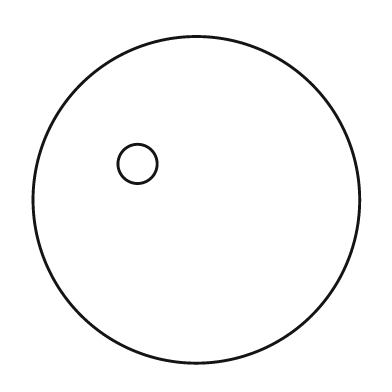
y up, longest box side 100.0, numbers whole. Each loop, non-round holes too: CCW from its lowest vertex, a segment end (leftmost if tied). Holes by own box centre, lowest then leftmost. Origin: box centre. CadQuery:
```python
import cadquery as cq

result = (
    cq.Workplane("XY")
    .moveTo(0.0, 0.0)
    .circle(50.0)
    .moveTo(-18.0, 11.0)
    .circle(6.0)
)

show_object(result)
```